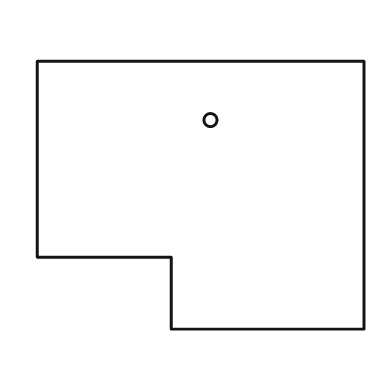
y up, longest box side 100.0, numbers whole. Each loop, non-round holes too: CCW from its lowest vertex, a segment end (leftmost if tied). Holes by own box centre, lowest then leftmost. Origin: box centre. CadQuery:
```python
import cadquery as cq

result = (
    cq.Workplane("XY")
    .moveTo(-9.0, -41.0)
    .lineTo(50.0, -41.0)
    .lineTo(50.0, 41.0)
    .lineTo(-50.0, 41.0)
    .lineTo(-50.0, -19.0)
    .lineTo(-9.0, -19.0)
    .close()
    .moveTo(3.0, 23.0)
    .circle(2.0)
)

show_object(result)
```